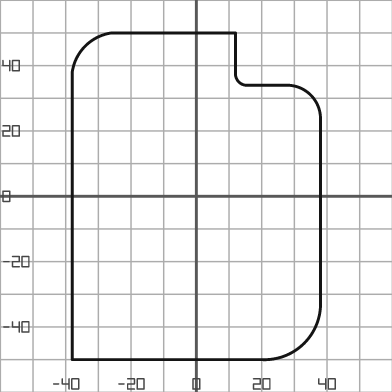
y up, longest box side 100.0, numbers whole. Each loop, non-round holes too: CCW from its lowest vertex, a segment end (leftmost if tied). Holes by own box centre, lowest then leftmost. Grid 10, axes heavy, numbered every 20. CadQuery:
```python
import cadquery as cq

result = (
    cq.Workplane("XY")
    .moveTo(-38.0, -50.0)
    .lineTo(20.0, -50.0)
    .threePointArc((33.0, -45.0), (38.0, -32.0))
    .lineTo(38.0, 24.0)
    .threePointArc((35.0, 31.0), (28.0, 34.0))
    .lineTo(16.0, 34.0)
    .threePointArc((13.0, 35.0), (12.0, 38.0))
    .lineTo(12.0, 50.0)
    .lineTo(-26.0, 50.0)
    .threePointArc((-34.0, 46.0), (-38.0, 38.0))
    .close()
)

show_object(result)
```